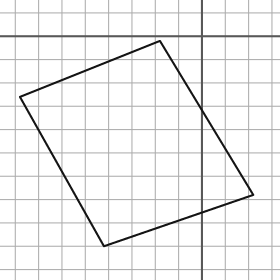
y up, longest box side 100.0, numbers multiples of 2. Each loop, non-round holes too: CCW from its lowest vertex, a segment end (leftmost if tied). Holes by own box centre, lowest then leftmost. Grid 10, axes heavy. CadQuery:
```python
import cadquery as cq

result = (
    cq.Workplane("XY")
    .moveTo(-42.0, -90.0)
    .lineTo(22.0, -68.0)
    .lineTo(-18.0, -2.0)
    .lineTo(-78.0, -26.0)
    .close()
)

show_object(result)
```